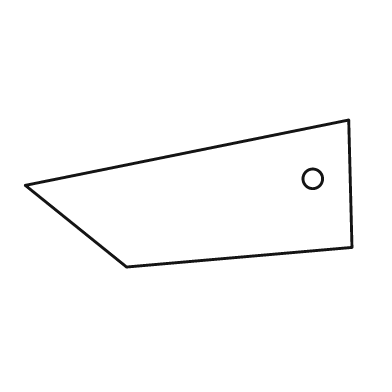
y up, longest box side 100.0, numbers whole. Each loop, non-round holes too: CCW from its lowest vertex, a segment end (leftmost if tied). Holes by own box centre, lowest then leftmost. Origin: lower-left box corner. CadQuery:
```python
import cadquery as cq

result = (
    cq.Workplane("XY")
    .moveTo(31.0, 0.0)
    .lineTo(100.0, 6.0)
    .lineTo(99.0, 45.0)
    .lineTo(0.0, 25.0)
    .close()
    .moveTo(88.0, 27.0)
    .circle(3.0)
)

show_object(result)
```